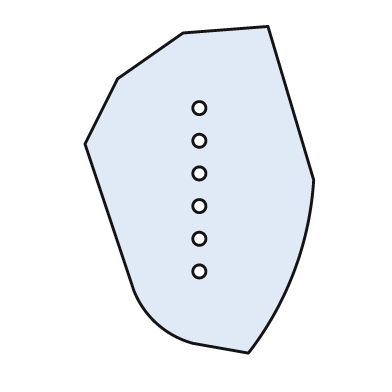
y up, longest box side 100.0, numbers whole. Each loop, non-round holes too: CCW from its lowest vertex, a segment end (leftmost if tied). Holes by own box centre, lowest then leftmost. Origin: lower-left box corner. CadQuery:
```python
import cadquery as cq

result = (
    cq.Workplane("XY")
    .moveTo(50.0, 0.0)
    .threePointArc((64.0, 25.0), (70.0, 53.0))
    .lineTo(56.0, 100.0)
    .lineTo(30.0, 98.0)
    .lineTo(10.0, 84.0)
    .lineTo(0.0, 64.0)
    .lineTo(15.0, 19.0)
    .threePointArc((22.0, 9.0), (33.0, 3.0))
    .close()
    .moveTo(35.0, 25.0)
    .circle(2.0)
    .moveTo(35.0, 35.0)
    .circle(2.0)
    .moveTo(35.0, 45.0)
    .circle(2.0)
    .moveTo(35.0, 55.0)
    .circle(2.0)
    .moveTo(35.0, 65.0)
    .circle(2.0)
    .moveTo(35.0, 75.0)
    .circle(2.0)
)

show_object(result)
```